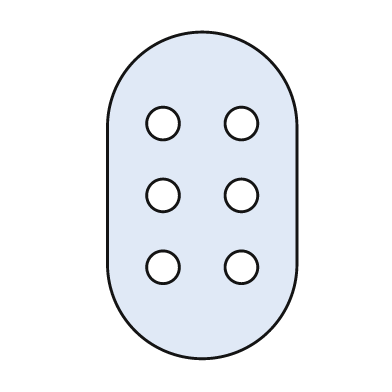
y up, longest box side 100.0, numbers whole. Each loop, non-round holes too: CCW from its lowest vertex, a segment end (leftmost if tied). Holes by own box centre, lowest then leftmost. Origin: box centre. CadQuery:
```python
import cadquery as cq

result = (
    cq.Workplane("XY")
    .moveTo(-29.0, -21.0)
    .threePointArc((0.0, -50.0), (29.0, -21.0))
    .lineTo(29.0, 21.0)
    .threePointArc((0.0, 50.0), (-29.0, 21.0))
    .close()
    .moveTo(-12.0, -22.0)
    .circle(5.0)
    .moveTo(12.0, -22.0)
    .circle(5.0)
    .moveTo(-12.0, 0.0)
    .circle(5.0)
    .moveTo(12.0, 0.0)
    .circle(5.0)
    .moveTo(-12.0, 22.0)
    .circle(5.0)
    .moveTo(12.0, 22.0)
    .circle(5.0)
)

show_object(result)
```